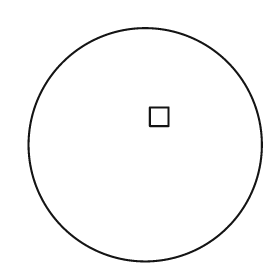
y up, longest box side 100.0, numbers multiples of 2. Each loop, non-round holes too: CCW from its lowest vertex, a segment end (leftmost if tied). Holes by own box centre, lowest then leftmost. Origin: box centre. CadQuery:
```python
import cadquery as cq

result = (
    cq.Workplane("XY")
    .moveTo(0.0, 0.0)
    .circle(50.0)
    .moveTo(2.0, 8.0)
    .lineTo(10.0, 8.0)
    .lineTo(10.0, 16.0)
    .lineTo(2.0, 16.0)
    .close()
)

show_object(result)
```